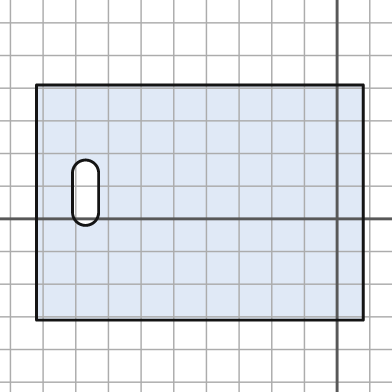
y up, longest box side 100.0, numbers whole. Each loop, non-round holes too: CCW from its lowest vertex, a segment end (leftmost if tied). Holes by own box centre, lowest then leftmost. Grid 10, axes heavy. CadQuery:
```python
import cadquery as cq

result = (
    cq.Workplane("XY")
    .moveTo(-92.0, -31.0)
    .lineTo(8.0, -31.0)
    .lineTo(8.0, 41.0)
    .lineTo(-92.0, 41.0)
    .close()
    .moveTo(-81.0, 2.0)
    .threePointArc((-77.0, -2.0), (-73.0, 2.0))
    .lineTo(-73.0, 14.0)
    .threePointArc((-77.0, 18.0), (-81.0, 14.0))
    .close()
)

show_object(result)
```